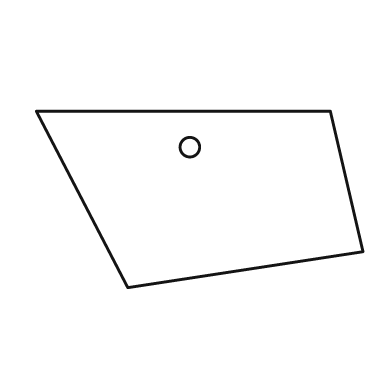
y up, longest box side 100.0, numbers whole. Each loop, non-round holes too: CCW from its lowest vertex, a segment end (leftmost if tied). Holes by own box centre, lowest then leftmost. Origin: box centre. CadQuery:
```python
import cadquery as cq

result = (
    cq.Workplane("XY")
    .moveTo(-22.0, -27.0)
    .lineTo(50.0, -16.0)
    .lineTo(40.0, 27.0)
    .lineTo(-50.0, 27.0)
    .close()
    .moveTo(-3.0, 16.0)
    .circle(3.0)
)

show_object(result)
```